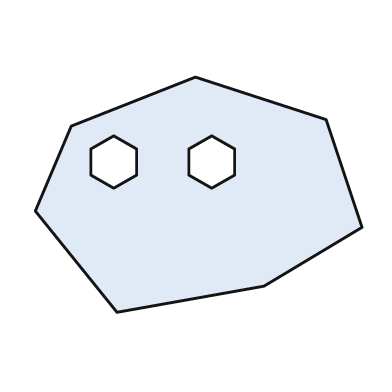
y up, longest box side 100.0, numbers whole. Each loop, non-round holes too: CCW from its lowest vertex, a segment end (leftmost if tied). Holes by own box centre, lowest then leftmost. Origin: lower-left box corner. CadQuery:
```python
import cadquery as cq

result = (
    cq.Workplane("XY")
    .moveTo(25.0, 0.0)
    .lineTo(70.0, 8.0)
    .lineTo(100.0, 26.0)
    .lineTo(89.0, 59.0)
    .lineTo(49.0, 72.0)
    .lineTo(11.0, 57.0)
    .lineTo(0.0, 31.0)
    .close()
    .moveTo(24.0, 38.0)
    .lineTo(31.0, 42.0)
    .lineTo(31.0, 50.0)
    .lineTo(24.0, 54.0)
    .lineTo(17.0, 50.0)
    .lineTo(17.0, 42.0)
    .close()
    .moveTo(54.0, 38.0)
    .lineTo(61.0, 42.0)
    .lineTo(61.0, 50.0)
    .lineTo(54.0, 54.0)
    .lineTo(47.0, 50.0)
    .lineTo(47.0, 42.0)
    .close()
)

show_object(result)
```